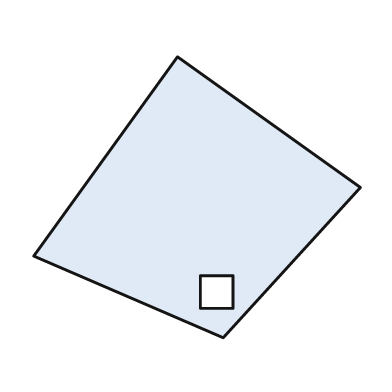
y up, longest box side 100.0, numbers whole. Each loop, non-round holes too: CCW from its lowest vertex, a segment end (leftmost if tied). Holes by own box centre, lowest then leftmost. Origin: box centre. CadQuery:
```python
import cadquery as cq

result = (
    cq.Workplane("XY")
    .moveTo(8.0, -43.0)
    .lineTo(50.0, 3.0)
    .lineTo(-6.0, 43.0)
    .lineTo(-50.0, -18.0)
    .close()
    .moveTo(1.0, -34.0)
    .lineTo(11.0, -34.0)
    .lineTo(11.0, -24.0)
    .lineTo(1.0, -24.0)
    .close()
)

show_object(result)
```